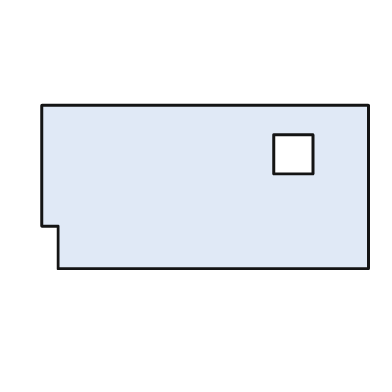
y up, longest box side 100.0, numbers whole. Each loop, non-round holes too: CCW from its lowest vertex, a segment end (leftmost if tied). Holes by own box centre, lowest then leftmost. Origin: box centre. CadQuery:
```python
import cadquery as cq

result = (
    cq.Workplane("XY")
    .moveTo(-45.0, -25.0)
    .lineTo(50.0, -25.0)
    .lineTo(50.0, 25.0)
    .lineTo(-50.0, 25.0)
    .lineTo(-50.0, -12.0)
    .lineTo(-45.0, -12.0)
    .close()
    .moveTo(21.0, 4.0)
    .lineTo(33.0, 4.0)
    .lineTo(33.0, 16.0)
    .lineTo(21.0, 16.0)
    .close()
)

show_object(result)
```